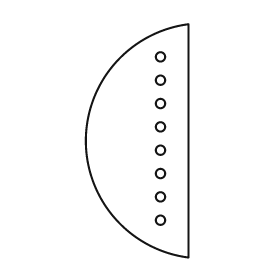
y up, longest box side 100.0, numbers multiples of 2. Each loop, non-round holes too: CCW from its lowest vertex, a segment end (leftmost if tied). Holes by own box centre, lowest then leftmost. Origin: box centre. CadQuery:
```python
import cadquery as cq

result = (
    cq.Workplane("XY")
    .moveTo(22.0, -50.0)
    .lineTo(22.0, 50.0)
    .threePointArc((-22.0, 0.0), (22.0, -50.0))
    .close()
    .moveTo(10.0, -34.0)
    .circle(2.0)
    .moveTo(10.0, -24.0)
    .circle(2.0)
    .moveTo(10.0, -14.0)
    .circle(2.0)
    .moveTo(10.0, -4.0)
    .circle(2.0)
    .moveTo(10.0, 6.0)
    .circle(2.0)
    .moveTo(10.0, 16.0)
    .circle(2.0)
    .moveTo(10.0, 26.0)
    .circle(2.0)
    .moveTo(10.0, 36.0)
    .circle(2.0)
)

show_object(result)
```